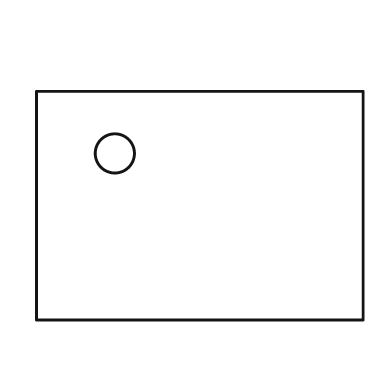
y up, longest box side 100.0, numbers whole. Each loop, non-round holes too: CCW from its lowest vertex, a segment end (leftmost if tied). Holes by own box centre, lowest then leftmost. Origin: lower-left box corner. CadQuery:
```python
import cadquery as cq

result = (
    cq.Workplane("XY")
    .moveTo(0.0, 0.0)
    .lineTo(100.0, 0.0)
    .lineTo(100.0, 70.0)
    .lineTo(0.0, 70.0)
    .close()
    .moveTo(24.0, 51.0)
    .circle(6.0)
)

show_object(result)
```